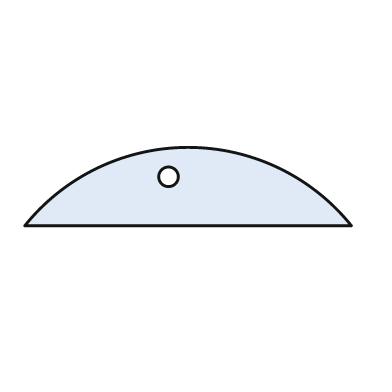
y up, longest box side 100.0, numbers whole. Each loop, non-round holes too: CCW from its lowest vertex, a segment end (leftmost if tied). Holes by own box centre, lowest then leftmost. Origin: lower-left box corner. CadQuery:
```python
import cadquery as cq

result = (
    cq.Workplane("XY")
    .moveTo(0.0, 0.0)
    .lineTo(100.0, 0.0)
    .threePointArc((50.0, 24.0), (0.0, 0.0))
    .close()
    .moveTo(44.0, 15.0)
    .circle(3.0)
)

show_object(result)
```